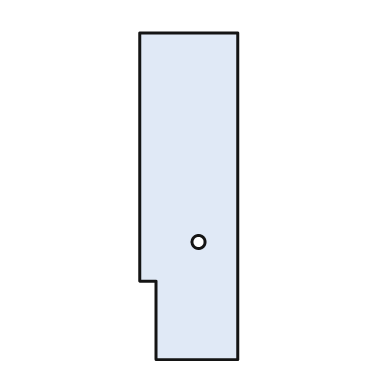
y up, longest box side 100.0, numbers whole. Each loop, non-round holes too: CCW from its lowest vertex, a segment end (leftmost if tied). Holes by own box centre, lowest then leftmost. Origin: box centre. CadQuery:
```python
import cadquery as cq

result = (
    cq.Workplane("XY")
    .moveTo(-10.0, -50.0)
    .lineTo(15.0, -50.0)
    .lineTo(15.0, 50.0)
    .lineTo(-15.0, 50.0)
    .lineTo(-15.0, -26.0)
    .lineTo(-10.0, -26.0)
    .close()
    .moveTo(3.0, -14.0)
    .circle(2.0)
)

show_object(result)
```